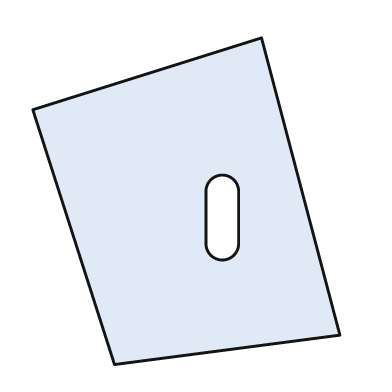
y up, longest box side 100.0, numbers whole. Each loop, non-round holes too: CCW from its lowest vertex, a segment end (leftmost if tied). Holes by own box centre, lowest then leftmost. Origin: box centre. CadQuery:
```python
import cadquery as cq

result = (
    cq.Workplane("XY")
    .moveTo(-22.0, -50.0)
    .lineTo(47.0, -41.0)
    .lineTo(23.0, 50.0)
    .lineTo(-47.0, 28.0)
    .close()
    .moveTo(6.0, -13.0)
    .threePointArc((11.0, -18.0), (16.0, -13.0))
    .lineTo(16.0, 3.0)
    .threePointArc((11.0, 8.0), (6.0, 3.0))
    .close()
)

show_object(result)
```